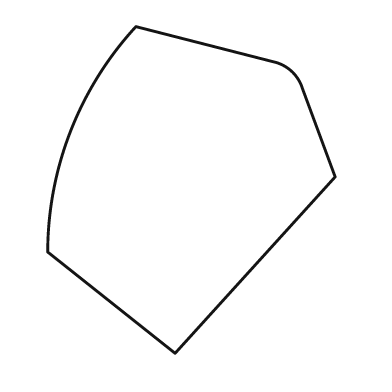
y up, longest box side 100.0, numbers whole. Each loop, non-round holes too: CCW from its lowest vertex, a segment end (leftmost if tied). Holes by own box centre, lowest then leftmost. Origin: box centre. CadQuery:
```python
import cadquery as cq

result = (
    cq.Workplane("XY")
    .moveTo(-5.0, -50.0)
    .lineTo(44.0, 4.0)
    .lineTo(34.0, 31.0)
    .threePointArc((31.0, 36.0), (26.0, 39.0))
    .lineTo(-17.0, 50.0)
    .threePointArc((-37.0, 18.0), (-44.0, -19.0))
    .close()
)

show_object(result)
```